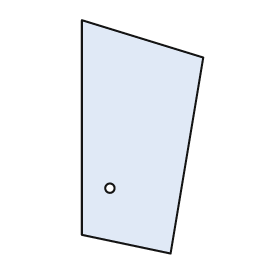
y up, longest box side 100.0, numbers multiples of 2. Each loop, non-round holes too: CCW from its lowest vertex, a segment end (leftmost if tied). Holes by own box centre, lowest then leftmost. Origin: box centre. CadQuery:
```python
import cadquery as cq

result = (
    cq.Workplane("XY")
    .moveTo(12.0, -50.0)
    .lineTo(26.0, 34.0)
    .lineTo(-26.0, 50.0)
    .lineTo(-26.0, -42.0)
    .close()
    .moveTo(-14.0, -22.0)
    .circle(2.0)
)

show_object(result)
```